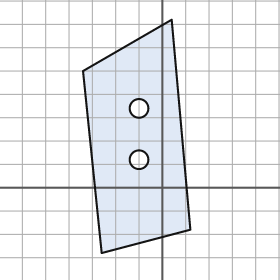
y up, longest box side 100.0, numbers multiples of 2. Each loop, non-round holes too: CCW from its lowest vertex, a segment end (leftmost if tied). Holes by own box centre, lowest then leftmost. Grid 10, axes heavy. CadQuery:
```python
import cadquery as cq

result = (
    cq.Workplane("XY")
    .moveTo(-26.0, -28.0)
    .lineTo(12.0, -18.0)
    .lineTo(4.0, 72.0)
    .lineTo(-34.0, 50.0)
    .close()
    .moveTo(-10.0, 12.0)
    .circle(4.0)
    .moveTo(-10.0, 34.0)
    .circle(4.0)
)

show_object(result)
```